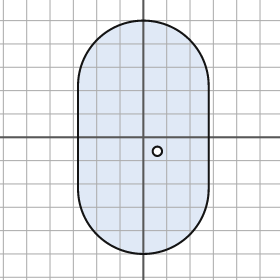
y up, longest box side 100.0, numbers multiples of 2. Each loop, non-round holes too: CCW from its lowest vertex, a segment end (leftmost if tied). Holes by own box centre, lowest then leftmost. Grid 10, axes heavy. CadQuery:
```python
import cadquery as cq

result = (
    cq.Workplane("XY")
    .moveTo(-28.0, -22.0)
    .threePointArc((0.0, -50.0), (28.0, -22.0))
    .lineTo(28.0, 22.0)
    .threePointArc((0.0, 50.0), (-28.0, 22.0))
    .close()
    .moveTo(6.0, -6.0)
    .circle(2.0)
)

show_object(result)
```